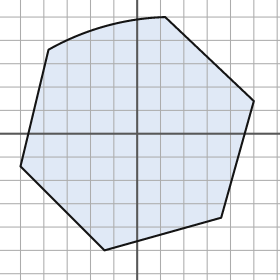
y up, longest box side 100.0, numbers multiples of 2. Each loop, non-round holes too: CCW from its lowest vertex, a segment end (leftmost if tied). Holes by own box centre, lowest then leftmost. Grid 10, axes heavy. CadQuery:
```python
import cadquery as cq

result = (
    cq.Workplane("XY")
    .moveTo(-14.0, -50.0)
    .lineTo(36.0, -36.0)
    .lineTo(50.0, 14.0)
    .lineTo(12.0, 50.0)
    .threePointArc((-14.0, 46.0), (-38.0, 36.0))
    .lineTo(-50.0, -14.0)
    .close()
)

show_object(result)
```